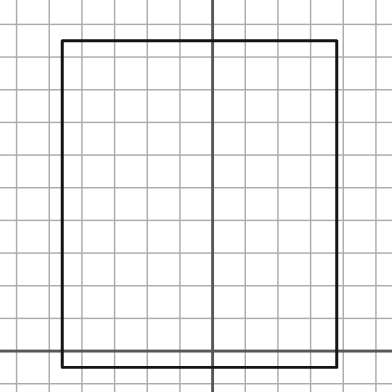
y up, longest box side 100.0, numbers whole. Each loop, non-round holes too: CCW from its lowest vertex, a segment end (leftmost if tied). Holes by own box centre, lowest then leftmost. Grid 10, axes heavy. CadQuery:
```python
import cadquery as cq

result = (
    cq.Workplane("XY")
    .moveTo(-46.0, -5.0)
    .lineTo(38.0, -5.0)
    .lineTo(38.0, 95.0)
    .lineTo(-46.0, 95.0)
    .close()
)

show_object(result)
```